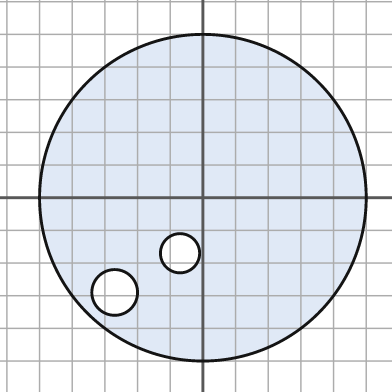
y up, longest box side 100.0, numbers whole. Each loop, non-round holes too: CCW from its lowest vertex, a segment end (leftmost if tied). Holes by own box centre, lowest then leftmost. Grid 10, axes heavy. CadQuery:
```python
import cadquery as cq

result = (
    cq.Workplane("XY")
    .moveTo(0.0, 0.0)
    .circle(50.0)
    .moveTo(-27.0, -29.0)
    .circle(7.0)
    .moveTo(-7.0, -17.0)
    .circle(6.0)
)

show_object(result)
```